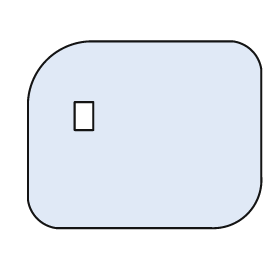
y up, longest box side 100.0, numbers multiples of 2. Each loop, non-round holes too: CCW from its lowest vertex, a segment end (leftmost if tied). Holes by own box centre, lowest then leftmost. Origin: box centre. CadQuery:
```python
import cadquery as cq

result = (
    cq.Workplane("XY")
    .moveTo(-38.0, -40.0)
    .lineTo(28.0, -40.0)
    .threePointArc((44.0, -34.0), (50.0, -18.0))
    .lineTo(50.0, 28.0)
    .threePointArc((46.0, 36.0), (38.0, 40.0))
    .lineTo(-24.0, 40.0)
    .threePointArc((-42.0, 32.0), (-50.0, 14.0))
    .lineTo(-50.0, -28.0)
    .threePointArc((-46.0, -36.0), (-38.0, -40.0))
    .close()
    .moveTo(-30.0, 2.0)
    .lineTo(-22.0, 2.0)
    .lineTo(-22.0, 14.0)
    .lineTo(-30.0, 14.0)
    .close()
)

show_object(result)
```